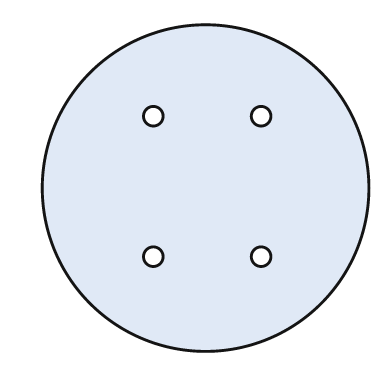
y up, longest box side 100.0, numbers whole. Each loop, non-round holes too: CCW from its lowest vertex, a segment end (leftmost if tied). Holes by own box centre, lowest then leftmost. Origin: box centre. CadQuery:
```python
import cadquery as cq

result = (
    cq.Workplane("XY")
    .moveTo(0.0, 0.0)
    .circle(50.0)
    .moveTo(-16.0, -21.0)
    .circle(3.0)
    .moveTo(17.0, -21.0)
    .circle(3.0)
    .moveTo(-16.0, 22.0)
    .circle(3.0)
    .moveTo(17.0, 22.0)
    .circle(3.0)
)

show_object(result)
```